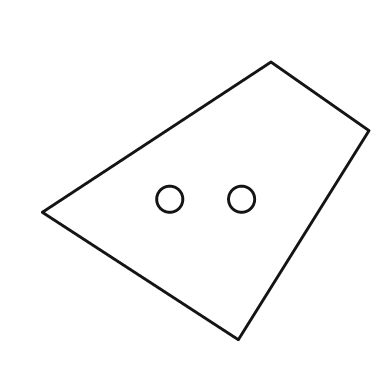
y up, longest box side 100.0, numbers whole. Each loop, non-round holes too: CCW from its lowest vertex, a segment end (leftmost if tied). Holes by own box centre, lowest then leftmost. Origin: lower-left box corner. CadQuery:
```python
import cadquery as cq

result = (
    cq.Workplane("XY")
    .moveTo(60.0, 0.0)
    .lineTo(100.0, 64.0)
    .lineTo(70.0, 85.0)
    .lineTo(0.0, 39.0)
    .close()
    .moveTo(39.0, 43.0)
    .circle(4.0)
    .moveTo(61.0, 43.0)
    .circle(4.0)
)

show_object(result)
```